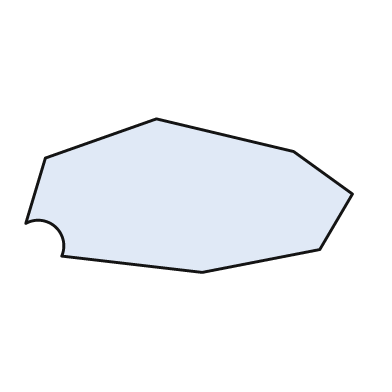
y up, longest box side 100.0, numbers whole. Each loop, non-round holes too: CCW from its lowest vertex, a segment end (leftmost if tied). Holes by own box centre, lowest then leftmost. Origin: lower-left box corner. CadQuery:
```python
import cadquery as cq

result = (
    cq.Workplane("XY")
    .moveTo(54.0, 0.0)
    .lineTo(90.0, 7.0)
    .lineTo(100.0, 24.0)
    .lineTo(82.0, 37.0)
    .lineTo(40.0, 47.0)
    .lineTo(6.0, 35.0)
    .lineTo(0.0, 15.0)
    .threePointArc((9.0, 14.0), (11.0, 5.0))
    .close()
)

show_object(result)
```